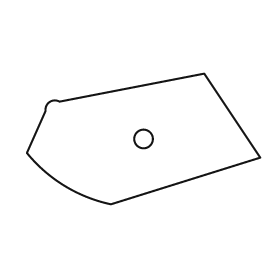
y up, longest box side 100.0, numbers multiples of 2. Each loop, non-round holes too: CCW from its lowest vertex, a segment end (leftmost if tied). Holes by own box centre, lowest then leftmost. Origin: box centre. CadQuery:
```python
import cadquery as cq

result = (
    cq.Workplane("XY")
    .moveTo(-14.0, -28.0)
    .lineTo(50.0, -8.0)
    .lineTo(26.0, 28.0)
    .lineTo(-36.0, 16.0)
    .threePointArc((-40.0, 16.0), (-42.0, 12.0))
    .lineTo(-50.0, -6.0)
    .threePointArc((-34.0, -20.0), (-14.0, -28.0))
    .close()
    .moveTo(0.0, 0.0)
    .circle(4.0)
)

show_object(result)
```